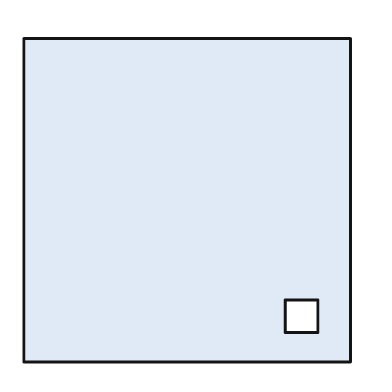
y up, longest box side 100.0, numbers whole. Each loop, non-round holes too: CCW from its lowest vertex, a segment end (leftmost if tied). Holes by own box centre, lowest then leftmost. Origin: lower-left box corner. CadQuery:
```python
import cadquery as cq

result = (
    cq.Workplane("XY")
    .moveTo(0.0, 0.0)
    .lineTo(100.0, 0.0)
    .lineTo(100.0, 99.0)
    .lineTo(0.0, 99.0)
    .close()
    .moveTo(80.0, 9.0)
    .lineTo(90.0, 9.0)
    .lineTo(90.0, 19.0)
    .lineTo(80.0, 19.0)
    .close()
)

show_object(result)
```